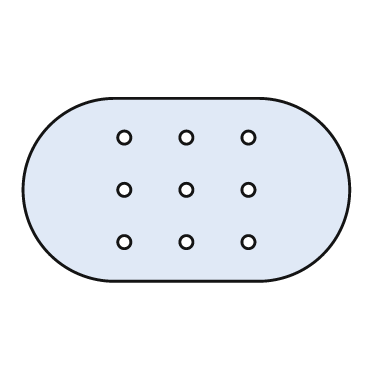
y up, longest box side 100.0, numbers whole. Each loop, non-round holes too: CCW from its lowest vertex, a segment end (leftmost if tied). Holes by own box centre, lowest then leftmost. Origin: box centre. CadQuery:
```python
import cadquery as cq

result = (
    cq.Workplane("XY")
    .moveTo(-22.0, -28.0)
    .lineTo(22.0, -28.0)
    .threePointArc((50.0, 0.0), (22.0, 28.0))
    .lineTo(-22.0, 28.0)
    .threePointArc((-50.0, 0.0), (-22.0, -28.0))
    .close()
    .moveTo(-19.0, -16.0)
    .circle(2.0)
    .moveTo(0.0, -16.0)
    .circle(2.0)
    .moveTo(19.0, -16.0)
    .circle(2.0)
    .moveTo(-19.0, 0.0)
    .circle(2.0)
    .moveTo(0.0, 0.0)
    .circle(2.0)
    .moveTo(19.0, 0.0)
    .circle(2.0)
    .moveTo(-19.0, 16.0)
    .circle(2.0)
    .moveTo(0.0, 16.0)
    .circle(2.0)
    .moveTo(19.0, 16.0)
    .circle(2.0)
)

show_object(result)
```